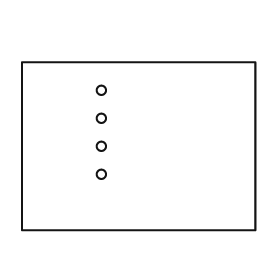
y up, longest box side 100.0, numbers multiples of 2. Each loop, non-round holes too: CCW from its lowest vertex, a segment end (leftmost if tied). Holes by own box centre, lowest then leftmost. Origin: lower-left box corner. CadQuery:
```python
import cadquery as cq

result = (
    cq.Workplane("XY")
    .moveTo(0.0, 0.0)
    .lineTo(100.0, 0.0)
    .lineTo(100.0, 72.0)
    .lineTo(0.0, 72.0)
    .close()
    .moveTo(34.0, 24.0)
    .circle(2.0)
    .moveTo(34.0, 36.0)
    .circle(2.0)
    .moveTo(34.0, 48.0)
    .circle(2.0)
    .moveTo(34.0, 60.0)
    .circle(2.0)
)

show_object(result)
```